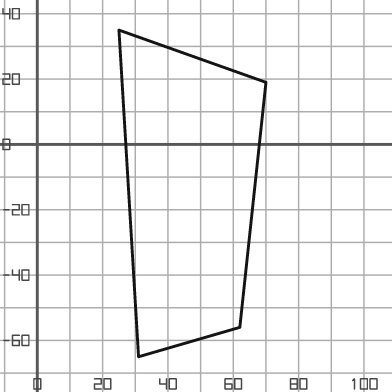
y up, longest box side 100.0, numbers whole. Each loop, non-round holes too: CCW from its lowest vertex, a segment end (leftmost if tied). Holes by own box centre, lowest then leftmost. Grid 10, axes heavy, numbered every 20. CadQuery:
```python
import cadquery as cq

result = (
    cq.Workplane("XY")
    .moveTo(31.0, -65.0)
    .lineTo(62.0, -56.0)
    .lineTo(70.0, 19.0)
    .lineTo(25.0, 35.0)
    .close()
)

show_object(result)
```